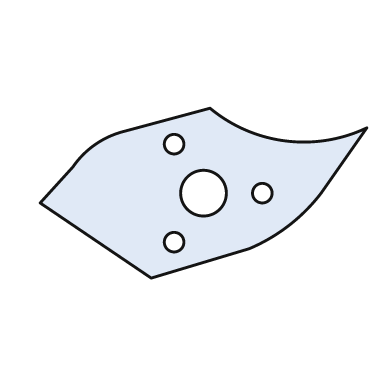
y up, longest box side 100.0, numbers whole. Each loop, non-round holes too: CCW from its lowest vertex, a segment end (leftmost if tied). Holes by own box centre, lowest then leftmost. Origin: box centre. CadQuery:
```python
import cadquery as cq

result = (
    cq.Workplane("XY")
    .moveTo(-16.0, -26.0)
    .lineTo(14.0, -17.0)
    .threePointArc((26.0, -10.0), (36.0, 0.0))
    .lineTo(50.0, 20.0)
    .threePointArc((25.0, 16.0), (2.0, 26.0))
    .lineTo(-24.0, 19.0)
    .threePointArc((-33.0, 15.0), (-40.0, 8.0))
    .lineTo(-50.0, -3.0)
    .close()
    .moveTo(-9.0, -15.0)
    .circle(3.0)
    .moveTo(0.0, 0.0)
    .circle(7.0)
    .moveTo(18.0, 0.0)
    .circle(3.0)
    .moveTo(-9.0, 15.0)
    .circle(3.0)
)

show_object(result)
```